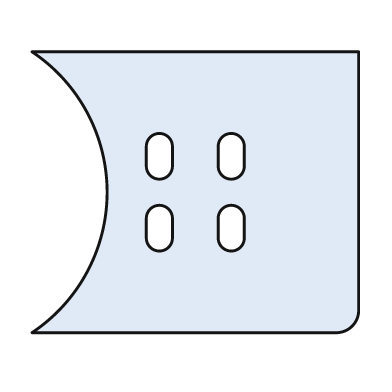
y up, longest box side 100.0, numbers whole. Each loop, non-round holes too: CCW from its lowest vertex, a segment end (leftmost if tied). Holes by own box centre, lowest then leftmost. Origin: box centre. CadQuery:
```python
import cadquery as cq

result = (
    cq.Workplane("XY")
    .moveTo(-50.0, -43.0)
    .lineTo(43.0, -43.0)
    .threePointArc((48.0, -41.0), (50.0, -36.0))
    .lineTo(50.0, 43.0)
    .lineTo(-50.0, 43.0)
    .threePointArc((-27.0, 0.0), (-50.0, -43.0))
    .close()
    .moveTo(-15.0, -14.0)
    .threePointArc((-11.0, -18.0), (-7.0, -14.0))
    .lineTo(-7.0, -8.0)
    .threePointArc((-11.0, -4.0), (-15.0, -8.0))
    .close()
    .moveTo(7.0, -14.0)
    .threePointArc((11.0, -18.0), (15.0, -14.0))
    .lineTo(15.0, -8.0)
    .threePointArc((11.0, -4.0), (7.0, -8.0))
    .close()
    .moveTo(-15.0, 8.0)
    .threePointArc((-11.0, 4.0), (-7.0, 8.0))
    .lineTo(-7.0, 14.0)
    .threePointArc((-11.0, 18.0), (-15.0, 14.0))
    .close()
    .moveTo(7.0, 8.0)
    .threePointArc((11.0, 4.0), (15.0, 8.0))
    .lineTo(15.0, 14.0)
    .threePointArc((11.0, 18.0), (7.0, 14.0))
    .close()
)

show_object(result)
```